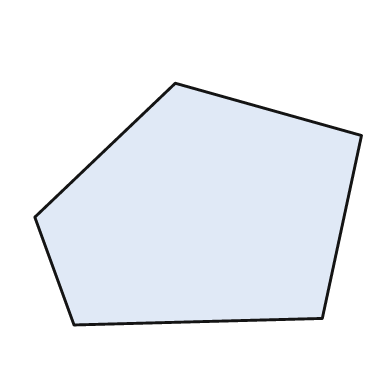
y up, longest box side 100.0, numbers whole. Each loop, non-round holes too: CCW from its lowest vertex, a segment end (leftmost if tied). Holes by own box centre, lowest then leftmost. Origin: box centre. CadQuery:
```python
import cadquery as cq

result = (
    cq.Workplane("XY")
    .moveTo(-38.0, -37.0)
    .lineTo(38.0, -35.0)
    .lineTo(50.0, 21.0)
    .lineTo(-7.0, 37.0)
    .lineTo(-50.0, -4.0)
    .close()
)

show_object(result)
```